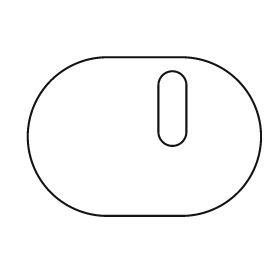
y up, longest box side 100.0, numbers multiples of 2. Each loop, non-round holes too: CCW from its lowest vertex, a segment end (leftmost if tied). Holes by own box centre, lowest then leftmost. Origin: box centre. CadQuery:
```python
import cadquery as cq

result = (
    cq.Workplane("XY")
    .moveTo(-16.0, -34.0)
    .lineTo(16.0, -34.0)
    .threePointArc((50.0, 0.0), (16.0, 34.0))
    .lineTo(-16.0, 34.0)
    .threePointArc((-50.0, 0.0), (-16.0, -34.0))
    .close()
    .moveTo(6.0, 2.0)
    .threePointArc((12.0, -4.0), (18.0, 2.0))
    .lineTo(18.0, 22.0)
    .threePointArc((12.0, 28.0), (6.0, 22.0))
    .close()
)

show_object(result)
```